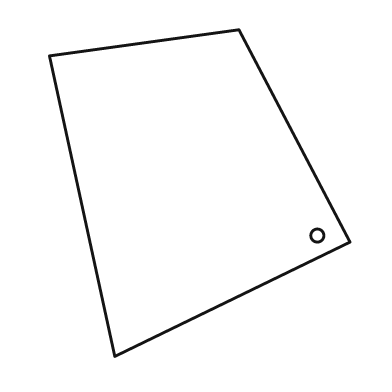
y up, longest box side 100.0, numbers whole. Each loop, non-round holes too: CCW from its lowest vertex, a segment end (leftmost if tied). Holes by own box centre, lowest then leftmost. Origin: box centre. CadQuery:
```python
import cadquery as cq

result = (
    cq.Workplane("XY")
    .moveTo(-26.0, -50.0)
    .lineTo(46.0, -15.0)
    .lineTo(12.0, 50.0)
    .lineTo(-46.0, 42.0)
    .close()
    .moveTo(36.0, -13.0)
    .circle(2.0)
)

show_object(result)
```